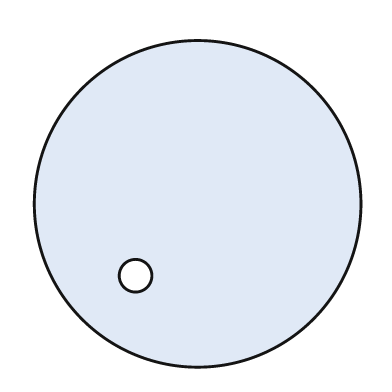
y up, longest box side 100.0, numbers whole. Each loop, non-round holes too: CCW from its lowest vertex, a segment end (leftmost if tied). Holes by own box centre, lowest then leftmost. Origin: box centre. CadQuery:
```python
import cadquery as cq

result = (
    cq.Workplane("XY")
    .moveTo(0.0, 0.0)
    .circle(50.0)
    .moveTo(-19.0, -22.0)
    .circle(5.0)
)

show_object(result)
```